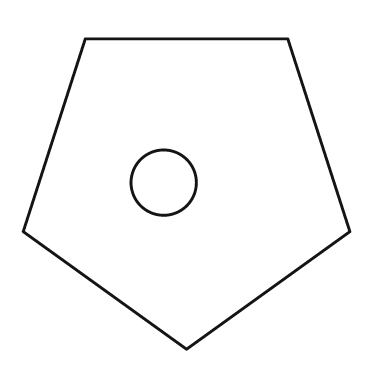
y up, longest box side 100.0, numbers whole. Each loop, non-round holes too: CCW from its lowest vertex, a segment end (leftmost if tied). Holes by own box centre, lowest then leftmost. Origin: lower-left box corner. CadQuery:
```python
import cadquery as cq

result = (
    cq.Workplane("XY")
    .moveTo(50.0, 0.0)
    .lineTo(100.0, 36.0)
    .lineTo(81.0, 95.0)
    .lineTo(19.0, 95.0)
    .lineTo(0.0, 36.0)
    .close()
    .moveTo(43.0, 51.0)
    .circle(10.0)
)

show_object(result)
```